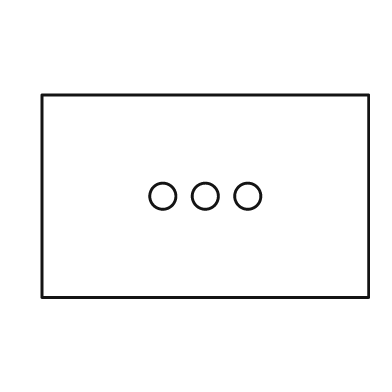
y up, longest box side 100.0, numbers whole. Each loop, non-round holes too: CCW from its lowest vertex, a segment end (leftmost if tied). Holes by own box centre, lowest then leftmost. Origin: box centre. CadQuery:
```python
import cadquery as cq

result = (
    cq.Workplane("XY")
    .moveTo(-50.0, -31.0)
    .lineTo(50.0, -31.0)
    .lineTo(50.0, 31.0)
    .lineTo(-50.0, 31.0)
    .close()
    .moveTo(-13.0, 0.0)
    .circle(4.0)
    .moveTo(0.0, 0.0)
    .circle(4.0)
    .moveTo(13.0, 0.0)
    .circle(4.0)
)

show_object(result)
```